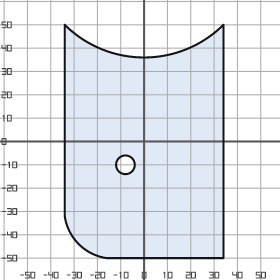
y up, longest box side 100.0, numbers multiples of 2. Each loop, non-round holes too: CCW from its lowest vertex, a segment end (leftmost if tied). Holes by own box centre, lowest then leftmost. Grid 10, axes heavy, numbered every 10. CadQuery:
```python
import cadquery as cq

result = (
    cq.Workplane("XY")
    .moveTo(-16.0, -50.0)
    .lineTo(34.0, -50.0)
    .lineTo(34.0, 50.0)
    .threePointArc((0.0, 36.0), (-34.0, 50.0))
    .lineTo(-34.0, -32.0)
    .threePointArc((-28.0, -44.0), (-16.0, -50.0))
    .close()
    .moveTo(-8.0, -10.0)
    .circle(4.0)
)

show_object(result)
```